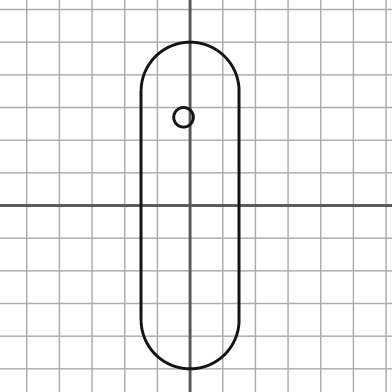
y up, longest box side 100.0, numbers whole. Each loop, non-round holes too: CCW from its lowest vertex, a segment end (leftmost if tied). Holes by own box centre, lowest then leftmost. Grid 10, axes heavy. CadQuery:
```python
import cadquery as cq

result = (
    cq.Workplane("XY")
    .moveTo(-15.0, -35.0)
    .threePointArc((0.0, -50.0), (15.0, -35.0))
    .lineTo(15.0, 35.0)
    .threePointArc((0.0, 50.0), (-15.0, 35.0))
    .close()
    .moveTo(-2.0, 27.0)
    .circle(3.0)
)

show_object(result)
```